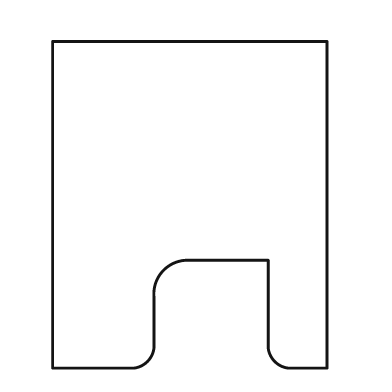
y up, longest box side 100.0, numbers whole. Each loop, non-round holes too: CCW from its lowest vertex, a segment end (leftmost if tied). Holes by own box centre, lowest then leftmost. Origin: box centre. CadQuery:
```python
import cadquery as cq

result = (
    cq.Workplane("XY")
    .moveTo(-42.0, -50.0)
    .lineTo(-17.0, -50.0)
    .threePointArc((-13.0, -48.0), (-11.0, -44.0))
    .lineTo(-11.0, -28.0)
    .threePointArc((-8.0, -20.0), (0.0, -17.0))
    .lineTo(24.0, -17.0)
    .lineTo(24.0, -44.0)
    .threePointArc((26.0, -48.0), (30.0, -50.0))
    .lineTo(42.0, -50.0)
    .lineTo(42.0, 50.0)
    .lineTo(-42.0, 50.0)
    .close()
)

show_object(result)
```